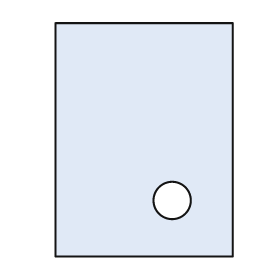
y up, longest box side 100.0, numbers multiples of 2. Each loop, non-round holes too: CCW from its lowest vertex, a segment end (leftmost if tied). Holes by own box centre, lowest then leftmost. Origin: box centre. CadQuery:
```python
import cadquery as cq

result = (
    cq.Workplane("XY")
    .moveTo(-38.0, -50.0)
    .lineTo(38.0, -50.0)
    .lineTo(38.0, 50.0)
    .lineTo(-38.0, 50.0)
    .close()
    .moveTo(12.0, -26.0)
    .circle(8.0)
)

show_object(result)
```